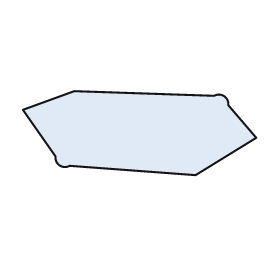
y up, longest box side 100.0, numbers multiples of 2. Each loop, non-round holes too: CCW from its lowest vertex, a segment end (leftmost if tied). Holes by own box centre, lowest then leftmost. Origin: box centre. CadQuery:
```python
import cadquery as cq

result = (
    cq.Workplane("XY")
    .moveTo(24.0, -18.0)
    .lineTo(50.0, -2.0)
    .lineTo(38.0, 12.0)
    .threePointArc((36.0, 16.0), (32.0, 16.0))
    .lineTo(-28.0, 18.0)
    .lineTo(-50.0, 10.0)
    .lineTo(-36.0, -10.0)
    .threePointArc((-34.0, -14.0), (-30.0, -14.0))
    .close()
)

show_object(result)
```